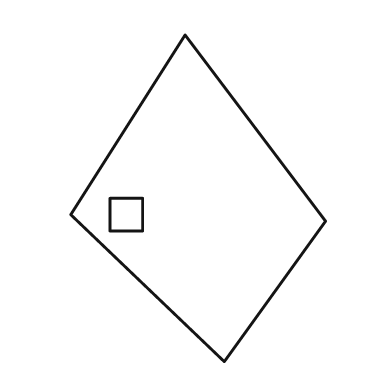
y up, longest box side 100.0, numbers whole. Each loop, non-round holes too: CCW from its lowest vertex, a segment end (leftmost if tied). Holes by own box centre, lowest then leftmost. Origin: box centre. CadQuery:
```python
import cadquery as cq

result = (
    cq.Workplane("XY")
    .moveTo(8.0, -50.0)
    .lineTo(39.0, -7.0)
    .lineTo(-4.0, 50.0)
    .lineTo(-39.0, -5.0)
    .close()
    .moveTo(-27.0, -10.0)
    .lineTo(-17.0, -10.0)
    .lineTo(-17.0, 0.0)
    .lineTo(-27.0, 0.0)
    .close()
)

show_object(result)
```